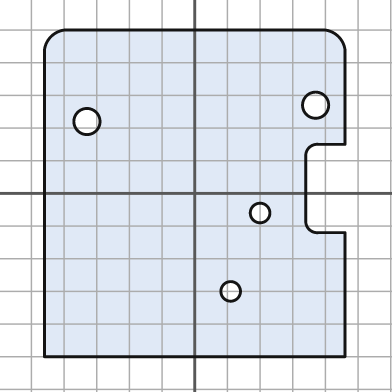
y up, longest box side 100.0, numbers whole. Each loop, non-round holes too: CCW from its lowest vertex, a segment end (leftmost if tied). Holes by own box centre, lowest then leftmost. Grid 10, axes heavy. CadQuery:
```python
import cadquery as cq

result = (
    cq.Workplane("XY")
    .moveTo(-46.0, -50.0)
    .lineTo(46.0, -50.0)
    .lineTo(46.0, -12.0)
    .lineTo(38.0, -12.0)
    .threePointArc((35.0, -11.0), (34.0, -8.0))
    .lineTo(34.0, 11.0)
    .threePointArc((35.0, 14.0), (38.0, 15.0))
    .lineTo(46.0, 15.0)
    .lineTo(46.0, 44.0)
    .threePointArc((44.0, 48.0), (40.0, 50.0))
    .lineTo(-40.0, 50.0)
    .threePointArc((-44.0, 48.0), (-46.0, 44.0))
    .close()
    .moveTo(11.0, -30.0)
    .circle(3.0)
    .moveTo(20.0, -6.0)
    .circle(3.0)
    .moveTo(-33.0, 22.0)
    .circle(4.0)
    .moveTo(37.0, 27.0)
    .circle(4.0)
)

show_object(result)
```